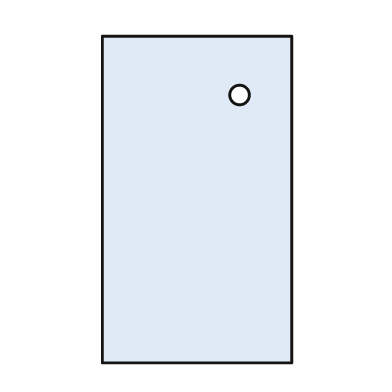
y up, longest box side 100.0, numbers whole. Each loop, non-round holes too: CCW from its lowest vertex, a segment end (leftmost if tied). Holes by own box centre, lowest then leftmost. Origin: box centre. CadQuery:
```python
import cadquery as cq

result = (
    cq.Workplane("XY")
    .moveTo(-29.0, -50.0)
    .lineTo(29.0, -50.0)
    .lineTo(29.0, 50.0)
    .lineTo(-29.0, 50.0)
    .close()
    .moveTo(13.0, 32.0)
    .circle(3.0)
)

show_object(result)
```